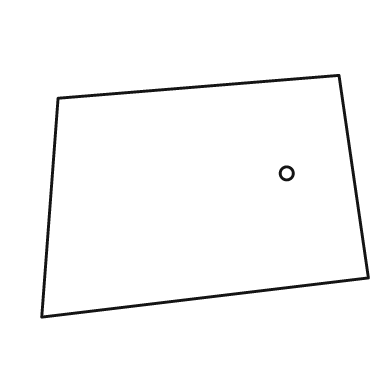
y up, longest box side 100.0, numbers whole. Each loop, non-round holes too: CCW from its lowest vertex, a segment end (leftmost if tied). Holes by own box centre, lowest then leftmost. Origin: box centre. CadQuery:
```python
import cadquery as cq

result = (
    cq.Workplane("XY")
    .moveTo(-50.0, -37.0)
    .lineTo(50.0, -25.0)
    .lineTo(41.0, 37.0)
    .lineTo(-45.0, 30.0)
    .close()
    .moveTo(25.0, 7.0)
    .circle(2.0)
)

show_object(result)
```